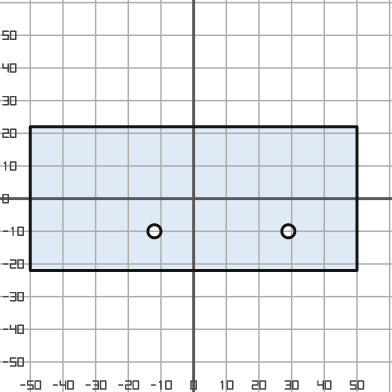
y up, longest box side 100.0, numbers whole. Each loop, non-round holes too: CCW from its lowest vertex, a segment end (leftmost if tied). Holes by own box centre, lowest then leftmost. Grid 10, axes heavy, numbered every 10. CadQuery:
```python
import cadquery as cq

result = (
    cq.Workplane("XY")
    .moveTo(-50.0, -22.0)
    .lineTo(50.0, -22.0)
    .lineTo(50.0, 22.0)
    .lineTo(-50.0, 22.0)
    .close()
    .moveTo(-12.0, -10.0)
    .circle(2.0)
    .moveTo(29.0, -10.0)
    .circle(2.0)
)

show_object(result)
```